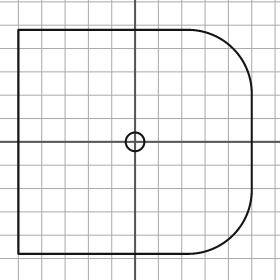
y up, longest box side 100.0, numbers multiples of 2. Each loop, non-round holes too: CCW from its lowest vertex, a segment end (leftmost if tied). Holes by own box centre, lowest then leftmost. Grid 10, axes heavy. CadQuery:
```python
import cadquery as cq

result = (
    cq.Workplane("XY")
    .moveTo(-50.0, -48.0)
    .lineTo(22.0, -48.0)
    .threePointArc((42.0, -40.0), (50.0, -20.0))
    .lineTo(50.0, 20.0)
    .threePointArc((42.0, 40.0), (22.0, 48.0))
    .lineTo(-50.0, 48.0)
    .close()
    .moveTo(0.0, 0.0)
    .circle(4.0)
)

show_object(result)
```